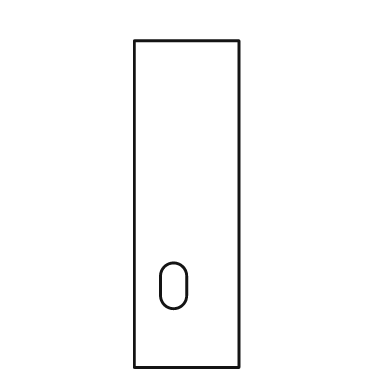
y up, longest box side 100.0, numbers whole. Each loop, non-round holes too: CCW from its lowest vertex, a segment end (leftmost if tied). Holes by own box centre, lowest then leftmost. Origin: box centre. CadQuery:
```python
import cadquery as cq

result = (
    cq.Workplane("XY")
    .moveTo(-16.0, -50.0)
    .lineTo(16.0, -50.0)
    .lineTo(16.0, 50.0)
    .lineTo(-16.0, 50.0)
    .close()
    .moveTo(-8.0, -28.0)
    .threePointArc((-4.0, -32.0), (0.0, -28.0))
    .lineTo(0.0, -22.0)
    .threePointArc((-4.0, -18.0), (-8.0, -22.0))
    .close()
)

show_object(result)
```